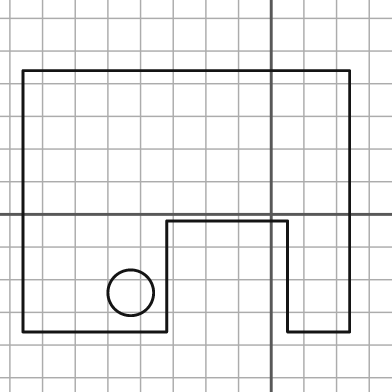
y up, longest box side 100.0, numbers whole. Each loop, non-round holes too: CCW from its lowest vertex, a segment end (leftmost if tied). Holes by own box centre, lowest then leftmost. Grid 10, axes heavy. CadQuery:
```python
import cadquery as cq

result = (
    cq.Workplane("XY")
    .moveTo(-76.0, -36.0)
    .lineTo(-32.0, -36.0)
    .lineTo(-32.0, -2.0)
    .lineTo(5.0, -2.0)
    .lineTo(5.0, -36.0)
    .lineTo(24.0, -36.0)
    .lineTo(24.0, 44.0)
    .lineTo(-76.0, 44.0)
    .close()
    .moveTo(-43.0, -24.0)
    .circle(7.0)
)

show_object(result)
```